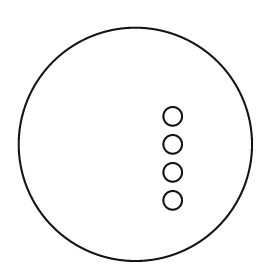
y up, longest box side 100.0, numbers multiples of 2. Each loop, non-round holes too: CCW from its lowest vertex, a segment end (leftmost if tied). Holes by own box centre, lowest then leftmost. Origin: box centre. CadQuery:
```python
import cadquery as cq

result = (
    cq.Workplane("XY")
    .moveTo(0.0, 0.0)
    .circle(50.0)
    .moveTo(16.0, -24.0)
    .circle(4.0)
    .moveTo(16.0, -12.0)
    .circle(4.0)
    .moveTo(16.0, 0.0)
    .circle(4.0)
    .moveTo(16.0, 12.0)
    .circle(4.0)
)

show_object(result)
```